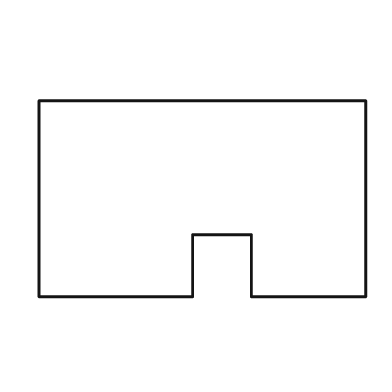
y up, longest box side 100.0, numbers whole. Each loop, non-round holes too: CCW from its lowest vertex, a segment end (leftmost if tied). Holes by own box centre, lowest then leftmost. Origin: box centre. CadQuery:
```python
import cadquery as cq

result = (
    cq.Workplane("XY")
    .moveTo(-50.0, -30.0)
    .lineTo(-3.0, -30.0)
    .lineTo(-3.0, -11.0)
    .lineTo(15.0, -11.0)
    .lineTo(15.0, -30.0)
    .lineTo(50.0, -30.0)
    .lineTo(50.0, 30.0)
    .lineTo(-50.0, 30.0)
    .close()
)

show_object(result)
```